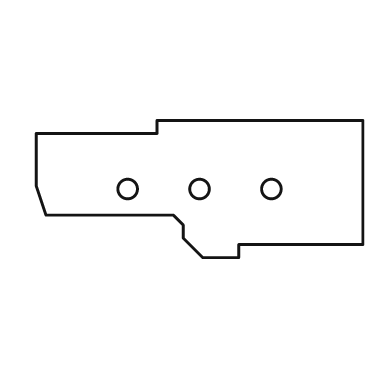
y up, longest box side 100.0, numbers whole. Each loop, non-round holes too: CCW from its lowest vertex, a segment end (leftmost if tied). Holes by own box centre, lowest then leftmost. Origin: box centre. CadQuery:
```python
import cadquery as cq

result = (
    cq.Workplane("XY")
    .moveTo(1.0, -21.0)
    .lineTo(12.0, -21.0)
    .lineTo(12.0, -17.0)
    .lineTo(50.0, -17.0)
    .lineTo(50.0, 21.0)
    .lineTo(-13.0, 21.0)
    .lineTo(-13.0, 17.0)
    .lineTo(-50.0, 17.0)
    .lineTo(-50.0, 1.0)
    .lineTo(-47.0, -8.0)
    .lineTo(-8.0, -8.0)
    .lineTo(-5.0, -11.0)
    .lineTo(-5.0, -15.0)
    .close()
    .moveTo(-22.0, 0.0)
    .circle(3.0)
    .moveTo(0.0, 0.0)
    .circle(3.0)
    .moveTo(22.0, 0.0)
    .circle(3.0)
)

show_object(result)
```